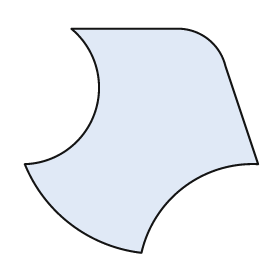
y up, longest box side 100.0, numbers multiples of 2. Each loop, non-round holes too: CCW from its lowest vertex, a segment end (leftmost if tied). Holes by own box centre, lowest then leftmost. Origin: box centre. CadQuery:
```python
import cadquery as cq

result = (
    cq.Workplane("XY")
    .moveTo(0.0, -48.0)
    .threePointArc((18.0, -20.0), (50.0, -10.0))
    .lineTo(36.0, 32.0)
    .threePointArc((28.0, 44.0), (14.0, 48.0))
    .lineTo(-30.0, 48.0)
    .threePointArc((-20.0, 12.0), (-50.0, -10.0))
    .threePointArc((-30.0, -36.0), (0.0, -48.0))
    .close()
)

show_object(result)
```